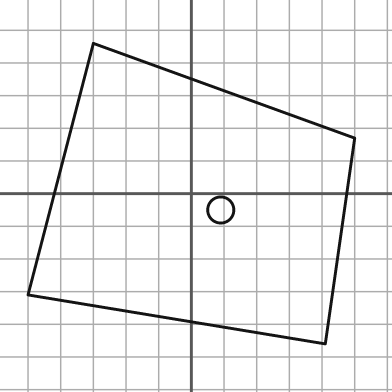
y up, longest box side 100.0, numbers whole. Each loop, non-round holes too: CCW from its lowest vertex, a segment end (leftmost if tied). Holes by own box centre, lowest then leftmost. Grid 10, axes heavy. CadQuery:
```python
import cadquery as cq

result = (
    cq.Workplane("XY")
    .moveTo(41.0, -46.0)
    .lineTo(50.0, 17.0)
    .lineTo(-30.0, 46.0)
    .lineTo(-50.0, -31.0)
    .close()
    .moveTo(9.0, -5.0)
    .circle(4.0)
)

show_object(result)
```